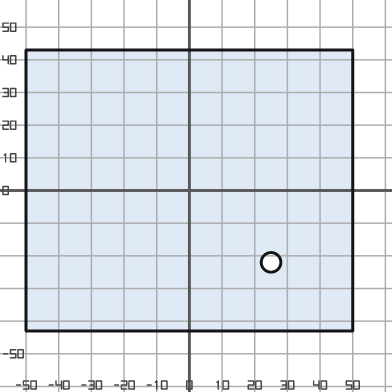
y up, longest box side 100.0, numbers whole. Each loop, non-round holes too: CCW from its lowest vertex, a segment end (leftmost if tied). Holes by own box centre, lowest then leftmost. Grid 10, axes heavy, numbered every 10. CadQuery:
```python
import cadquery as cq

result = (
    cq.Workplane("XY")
    .moveTo(-50.0, -43.0)
    .lineTo(50.0, -43.0)
    .lineTo(50.0, 43.0)
    .lineTo(-50.0, 43.0)
    .close()
    .moveTo(25.0, -22.0)
    .circle(3.0)
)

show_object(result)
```